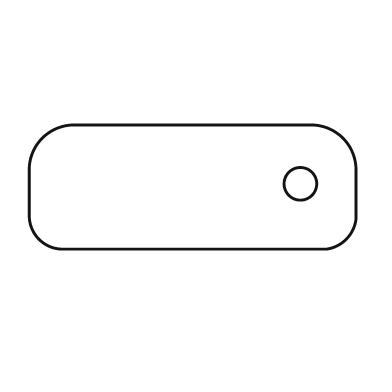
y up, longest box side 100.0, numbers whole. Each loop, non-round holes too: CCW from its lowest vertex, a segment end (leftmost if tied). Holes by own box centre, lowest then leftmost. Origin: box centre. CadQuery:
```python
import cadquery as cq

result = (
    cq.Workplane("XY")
    .moveTo(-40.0, -19.0)
    .lineTo(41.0, -19.0)
    .threePointArc((47.0, -16.0), (50.0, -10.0))
    .lineTo(50.0, 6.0)
    .threePointArc((46.0, 15.0), (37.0, 19.0))
    .lineTo(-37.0, 19.0)
    .threePointArc((-46.0, 15.0), (-50.0, 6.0))
    .lineTo(-50.0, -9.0)
    .threePointArc((-47.0, -16.0), (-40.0, -19.0))
    .close()
    .moveTo(33.0, 1.0)
    .circle(5.0)
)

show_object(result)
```